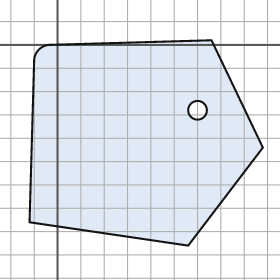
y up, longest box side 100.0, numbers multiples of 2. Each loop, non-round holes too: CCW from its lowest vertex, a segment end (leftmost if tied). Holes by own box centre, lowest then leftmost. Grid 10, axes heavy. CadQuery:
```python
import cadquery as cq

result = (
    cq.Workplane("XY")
    .moveTo(56.0, -86.0)
    .lineTo(88.0, -44.0)
    .lineTo(66.0, 2.0)
    .lineTo(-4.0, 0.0)
    .threePointArc((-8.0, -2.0), (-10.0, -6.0))
    .lineTo(-12.0, -76.0)
    .close()
    .moveTo(60.0, -28.0)
    .circle(4.0)
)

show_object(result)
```